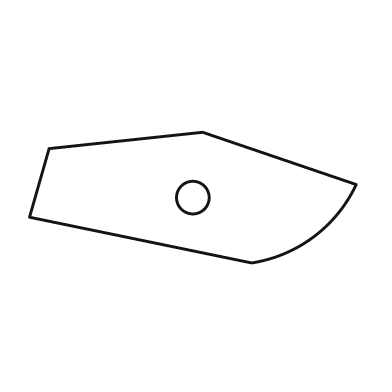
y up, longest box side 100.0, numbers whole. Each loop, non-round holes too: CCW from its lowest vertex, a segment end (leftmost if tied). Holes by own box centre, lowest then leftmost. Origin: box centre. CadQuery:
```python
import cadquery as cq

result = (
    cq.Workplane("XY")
    .moveTo(18.0, -20.0)
    .threePointArc((37.0, -12.0), (50.0, 4.0))
    .lineTo(3.0, 20.0)
    .lineTo(-44.0, 15.0)
    .lineTo(-50.0, -6.0)
    .close()
    .moveTo(0.0, 0.0)
    .circle(5.0)
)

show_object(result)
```